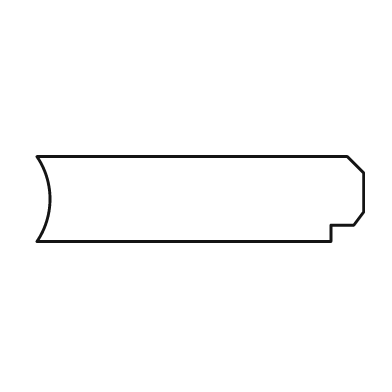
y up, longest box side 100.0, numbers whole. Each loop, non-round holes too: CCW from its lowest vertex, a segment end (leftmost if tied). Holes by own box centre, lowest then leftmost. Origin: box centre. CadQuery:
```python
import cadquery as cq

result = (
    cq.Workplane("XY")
    .moveTo(-50.0, -13.0)
    .lineTo(40.0, -13.0)
    .lineTo(40.0, -8.0)
    .lineTo(47.0, -8.0)
    .lineTo(50.0, -4.0)
    .lineTo(50.0, 8.0)
    .lineTo(45.0, 13.0)
    .lineTo(-50.0, 13.0)
    .threePointArc((-46.0, 0.0), (-50.0, -13.0))
    .close()
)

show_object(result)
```